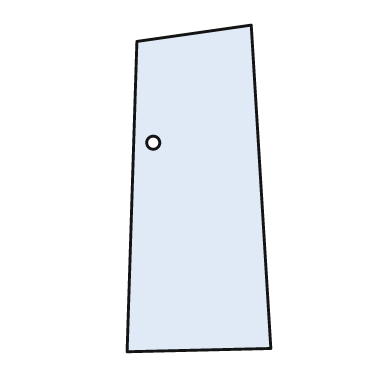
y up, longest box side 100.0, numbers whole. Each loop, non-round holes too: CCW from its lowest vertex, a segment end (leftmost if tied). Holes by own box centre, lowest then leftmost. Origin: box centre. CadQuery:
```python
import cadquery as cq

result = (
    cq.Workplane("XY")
    .moveTo(-22.0, -50.0)
    .lineTo(22.0, -49.0)
    .lineTo(16.0, 50.0)
    .lineTo(-19.0, 45.0)
    .close()
    .moveTo(-14.0, 14.0)
    .circle(2.0)
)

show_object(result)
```